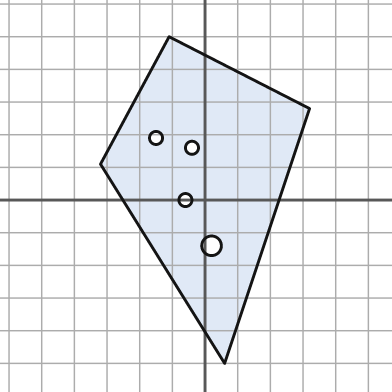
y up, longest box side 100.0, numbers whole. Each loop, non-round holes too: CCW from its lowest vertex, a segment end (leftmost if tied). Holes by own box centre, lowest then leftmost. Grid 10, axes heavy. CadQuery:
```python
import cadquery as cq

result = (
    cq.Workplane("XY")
    .moveTo(6.0, -50.0)
    .lineTo(32.0, 28.0)
    .lineTo(-11.0, 50.0)
    .lineTo(-32.0, 11.0)
    .close()
    .moveTo(2.0, -14.0)
    .circle(3.0)
    .moveTo(-6.0, 0.0)
    .circle(2.0)
    .moveTo(-4.0, 16.0)
    .circle(2.0)
    .moveTo(-15.0, 19.0)
    .circle(2.0)
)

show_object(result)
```